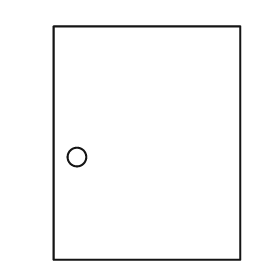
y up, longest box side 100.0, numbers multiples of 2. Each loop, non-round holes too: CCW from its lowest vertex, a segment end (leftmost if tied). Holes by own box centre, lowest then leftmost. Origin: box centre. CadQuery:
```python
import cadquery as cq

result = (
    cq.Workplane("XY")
    .moveTo(-40.0, -50.0)
    .lineTo(40.0, -50.0)
    .lineTo(40.0, 50.0)
    .lineTo(-40.0, 50.0)
    .close()
    .moveTo(-30.0, -6.0)
    .circle(4.0)
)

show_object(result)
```